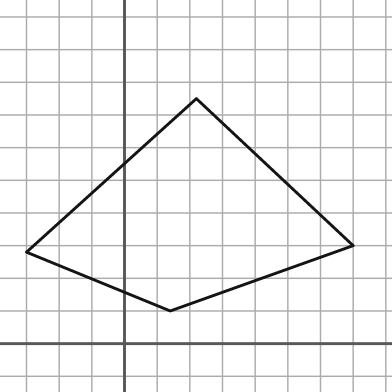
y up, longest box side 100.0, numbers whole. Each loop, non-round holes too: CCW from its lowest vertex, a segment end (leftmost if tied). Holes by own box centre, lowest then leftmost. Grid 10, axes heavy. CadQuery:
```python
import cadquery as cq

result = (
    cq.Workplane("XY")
    .moveTo(14.0, 10.0)
    .lineTo(70.0, 30.0)
    .lineTo(22.0, 75.0)
    .lineTo(-30.0, 28.0)
    .close()
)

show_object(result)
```